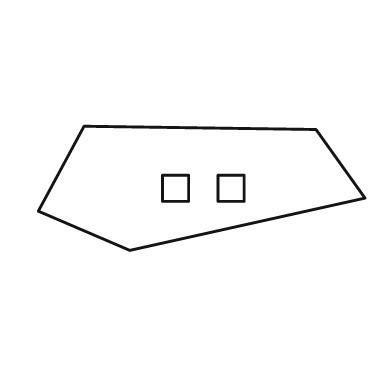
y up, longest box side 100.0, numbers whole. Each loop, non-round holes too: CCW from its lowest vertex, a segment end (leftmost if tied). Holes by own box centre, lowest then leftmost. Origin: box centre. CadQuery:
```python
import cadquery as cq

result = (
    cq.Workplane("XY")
    .moveTo(-22.0, -19.0)
    .lineTo(50.0, -3.0)
    .lineTo(35.0, 18.0)
    .lineTo(-36.0, 19.0)
    .lineTo(-50.0, -7.0)
    .close()
    .moveTo(-12.0, -4.0)
    .lineTo(-4.0, -4.0)
    .lineTo(-4.0, 4.0)
    .lineTo(-12.0, 4.0)
    .close()
    .moveTo(5.0, -4.0)
    .lineTo(13.0, -4.0)
    .lineTo(13.0, 4.0)
    .lineTo(5.0, 4.0)
    .close()
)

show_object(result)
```